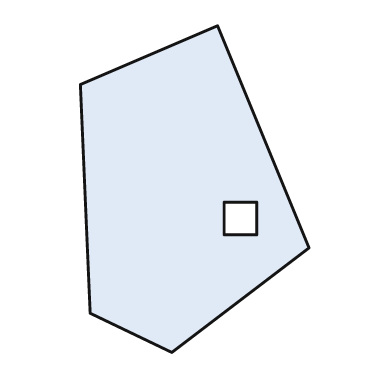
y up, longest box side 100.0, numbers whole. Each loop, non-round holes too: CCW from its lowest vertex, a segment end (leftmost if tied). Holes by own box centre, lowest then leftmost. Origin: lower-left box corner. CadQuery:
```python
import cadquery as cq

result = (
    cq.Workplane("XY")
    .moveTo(28.0, 0.0)
    .lineTo(70.0, 32.0)
    .lineTo(42.0, 100.0)
    .lineTo(0.0, 82.0)
    .lineTo(3.0, 12.0)
    .close()
    .moveTo(44.0, 36.0)
    .lineTo(54.0, 36.0)
    .lineTo(54.0, 46.0)
    .lineTo(44.0, 46.0)
    .close()
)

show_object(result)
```